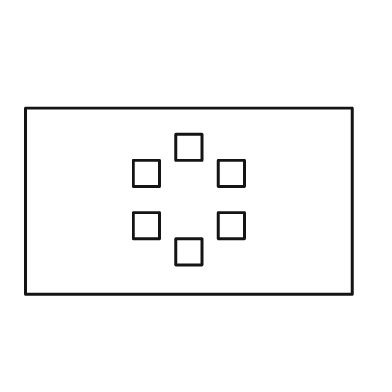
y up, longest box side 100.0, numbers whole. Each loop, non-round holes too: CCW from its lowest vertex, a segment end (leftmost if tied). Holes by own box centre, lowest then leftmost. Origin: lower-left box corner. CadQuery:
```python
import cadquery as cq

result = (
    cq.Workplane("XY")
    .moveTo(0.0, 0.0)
    .lineTo(100.0, 0.0)
    .lineTo(100.0, 57.0)
    .lineTo(0.0, 57.0)
    .close()
    .moveTo(46.0, 9.0)
    .lineTo(54.0, 9.0)
    .lineTo(54.0, 17.0)
    .lineTo(46.0, 17.0)
    .close()
    .moveTo(33.0, 17.0)
    .lineTo(41.0, 17.0)
    .lineTo(41.0, 25.0)
    .lineTo(33.0, 25.0)
    .close()
    .moveTo(59.0, 17.0)
    .lineTo(67.0, 17.0)
    .lineTo(67.0, 25.0)
    .lineTo(59.0, 25.0)
    .close()
    .moveTo(33.0, 33.0)
    .lineTo(41.0, 33.0)
    .lineTo(41.0, 41.0)
    .lineTo(33.0, 41.0)
    .close()
    .moveTo(59.0, 33.0)
    .lineTo(67.0, 33.0)
    .lineTo(67.0, 41.0)
    .lineTo(59.0, 41.0)
    .close()
    .moveTo(46.0, 41.0)
    .lineTo(54.0, 41.0)
    .lineTo(54.0, 49.0)
    .lineTo(46.0, 49.0)
    .close()
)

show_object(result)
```